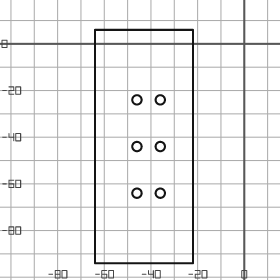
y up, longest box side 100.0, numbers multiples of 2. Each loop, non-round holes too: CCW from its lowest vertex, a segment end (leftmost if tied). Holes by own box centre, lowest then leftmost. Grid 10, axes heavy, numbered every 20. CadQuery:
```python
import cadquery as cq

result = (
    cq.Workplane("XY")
    .moveTo(-64.0, -94.0)
    .lineTo(-22.0, -94.0)
    .lineTo(-22.0, 6.0)
    .lineTo(-64.0, 6.0)
    .close()
    .moveTo(-46.0, -64.0)
    .circle(2.0)
    .moveTo(-36.0, -64.0)
    .circle(2.0)
    .moveTo(-46.0, -44.0)
    .circle(2.0)
    .moveTo(-36.0, -44.0)
    .circle(2.0)
    .moveTo(-46.0, -24.0)
    .circle(2.0)
    .moveTo(-36.0, -24.0)
    .circle(2.0)
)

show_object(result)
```